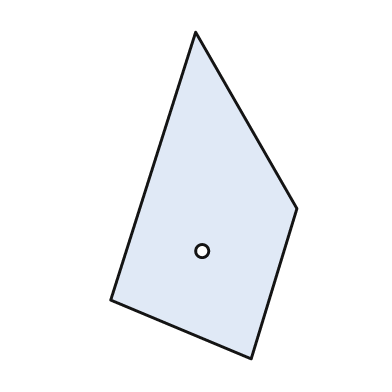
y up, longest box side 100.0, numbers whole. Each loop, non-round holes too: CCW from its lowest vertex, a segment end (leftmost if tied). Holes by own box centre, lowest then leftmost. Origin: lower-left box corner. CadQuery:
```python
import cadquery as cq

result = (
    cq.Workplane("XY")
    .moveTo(43.0, 0.0)
    .lineTo(57.0, 46.0)
    .lineTo(26.0, 100.0)
    .lineTo(0.0, 18.0)
    .close()
    .moveTo(28.0, 33.0)
    .circle(2.0)
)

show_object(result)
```